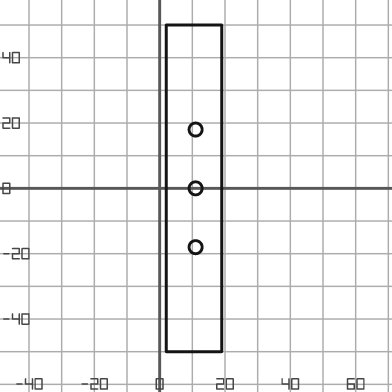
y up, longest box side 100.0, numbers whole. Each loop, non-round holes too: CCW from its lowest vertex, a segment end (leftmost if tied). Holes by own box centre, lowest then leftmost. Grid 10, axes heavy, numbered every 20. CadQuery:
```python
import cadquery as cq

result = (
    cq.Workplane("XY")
    .moveTo(2.0, -50.0)
    .lineTo(19.0, -50.0)
    .lineTo(19.0, 50.0)
    .lineTo(2.0, 50.0)
    .close()
    .moveTo(11.0, -18.0)
    .circle(2.0)
    .moveTo(11.0, 0.0)
    .circle(2.0)
    .moveTo(11.0, 18.0)
    .circle(2.0)
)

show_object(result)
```